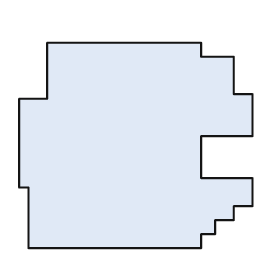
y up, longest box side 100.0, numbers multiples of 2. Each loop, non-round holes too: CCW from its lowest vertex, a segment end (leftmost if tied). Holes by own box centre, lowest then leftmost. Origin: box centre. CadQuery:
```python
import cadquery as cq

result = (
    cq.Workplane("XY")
    .moveTo(-46.0, -44.0)
    .lineTo(28.0, -44.0)
    .lineTo(28.0, -38.0)
    .lineTo(34.0, -38.0)
    .lineTo(34.0, -32.0)
    .lineTo(42.0, -32.0)
    .lineTo(42.0, -26.0)
    .lineTo(50.0, -26.0)
    .lineTo(50.0, -14.0)
    .lineTo(28.0, -14.0)
    .lineTo(28.0, 4.0)
    .lineTo(50.0, 4.0)
    .lineTo(50.0, 22.0)
    .lineTo(42.0, 22.0)
    .lineTo(42.0, 38.0)
    .lineTo(28.0, 38.0)
    .lineTo(28.0, 44.0)
    .lineTo(-38.0, 44.0)
    .lineTo(-38.0, 20.0)
    .lineTo(-50.0, 20.0)
    .lineTo(-50.0, -18.0)
    .lineTo(-46.0, -18.0)
    .close()
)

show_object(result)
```